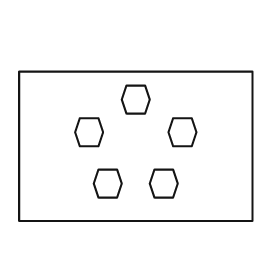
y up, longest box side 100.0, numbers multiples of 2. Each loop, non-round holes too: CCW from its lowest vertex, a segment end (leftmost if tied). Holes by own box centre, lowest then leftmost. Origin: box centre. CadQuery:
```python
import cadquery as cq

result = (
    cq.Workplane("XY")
    .moveTo(-50.0, -32.0)
    .lineTo(50.0, -32.0)
    .lineTo(50.0, 32.0)
    .lineTo(-50.0, 32.0)
    .close()
    .moveTo(-16.0, -22.0)
    .lineTo(-8.0, -22.0)
    .lineTo(-6.0, -16.0)
    .lineTo(-8.0, -10.0)
    .lineTo(-16.0, -10.0)
    .lineTo(-18.0, -16.0)
    .close()
    .moveTo(8.0, -22.0)
    .lineTo(16.0, -22.0)
    .lineTo(18.0, -16.0)
    .lineTo(16.0, -10.0)
    .lineTo(8.0, -10.0)
    .lineTo(6.0, -16.0)
    .close()
    .moveTo(-24.0, 0.0)
    .lineTo(-16.0, 0.0)
    .lineTo(-14.0, 6.0)
    .lineTo(-16.0, 12.0)
    .lineTo(-24.0, 12.0)
    .lineTo(-26.0, 6.0)
    .close()
    .moveTo(16.0, 0.0)
    .lineTo(24.0, 0.0)
    .lineTo(26.0, 6.0)
    .lineTo(24.0, 12.0)
    .lineTo(16.0, 12.0)
    .lineTo(14.0, 6.0)
    .close()
    .moveTo(-4.0, 14.0)
    .lineTo(4.0, 14.0)
    .lineTo(6.0, 20.0)
    .lineTo(4.0, 26.0)
    .lineTo(-4.0, 26.0)
    .lineTo(-6.0, 20.0)
    .close()
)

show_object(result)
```